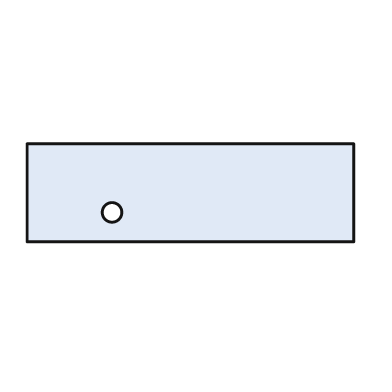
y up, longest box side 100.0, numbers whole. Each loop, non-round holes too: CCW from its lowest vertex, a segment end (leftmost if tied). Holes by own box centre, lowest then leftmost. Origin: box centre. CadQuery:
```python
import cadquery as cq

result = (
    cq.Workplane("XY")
    .moveTo(-50.0, -15.0)
    .lineTo(50.0, -15.0)
    .lineTo(50.0, 15.0)
    .lineTo(-50.0, 15.0)
    .close()
    .moveTo(-24.0, -6.0)
    .circle(3.0)
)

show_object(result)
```